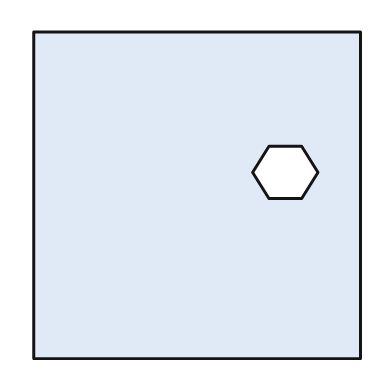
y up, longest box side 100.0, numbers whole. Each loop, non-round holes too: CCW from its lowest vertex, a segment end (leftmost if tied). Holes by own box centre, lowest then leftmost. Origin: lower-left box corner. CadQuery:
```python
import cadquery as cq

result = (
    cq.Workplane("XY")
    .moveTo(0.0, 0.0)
    .lineTo(100.0, 0.0)
    .lineTo(100.0, 100.0)
    .lineTo(0.0, 100.0)
    .close()
    .moveTo(72.0, 49.0)
    .lineTo(82.0, 49.0)
    .lineTo(87.0, 57.0)
    .lineTo(82.0, 65.0)
    .lineTo(72.0, 65.0)
    .lineTo(67.0, 57.0)
    .close()
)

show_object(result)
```